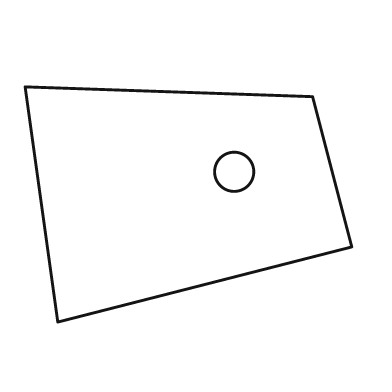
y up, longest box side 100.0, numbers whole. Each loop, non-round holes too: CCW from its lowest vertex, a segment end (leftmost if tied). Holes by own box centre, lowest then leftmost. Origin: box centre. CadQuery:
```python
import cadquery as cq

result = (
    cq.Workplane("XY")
    .moveTo(-40.0, -36.0)
    .lineTo(50.0, -13.0)
    .lineTo(38.0, 33.0)
    .lineTo(-50.0, 36.0)
    .close()
    .moveTo(14.0, 10.0)
    .circle(6.0)
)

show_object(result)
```